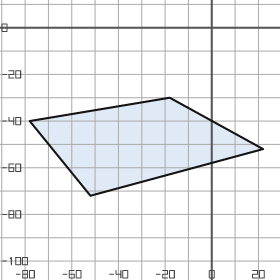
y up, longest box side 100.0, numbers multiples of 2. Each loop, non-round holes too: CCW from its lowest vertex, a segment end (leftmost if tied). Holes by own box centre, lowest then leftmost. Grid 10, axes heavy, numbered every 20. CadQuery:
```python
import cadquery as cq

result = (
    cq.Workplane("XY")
    .moveTo(-52.0, -72.0)
    .lineTo(22.0, -52.0)
    .lineTo(-18.0, -30.0)
    .lineTo(-78.0, -40.0)
    .close()
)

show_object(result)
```